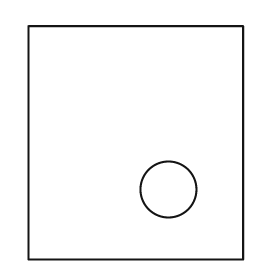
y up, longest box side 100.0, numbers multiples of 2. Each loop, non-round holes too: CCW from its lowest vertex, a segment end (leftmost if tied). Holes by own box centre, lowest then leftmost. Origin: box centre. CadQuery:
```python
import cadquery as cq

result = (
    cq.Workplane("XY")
    .moveTo(-46.0, -50.0)
    .lineTo(46.0, -50.0)
    .lineTo(46.0, 50.0)
    .lineTo(-46.0, 50.0)
    .close()
    .moveTo(14.0, -20.0)
    .circle(12.0)
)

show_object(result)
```